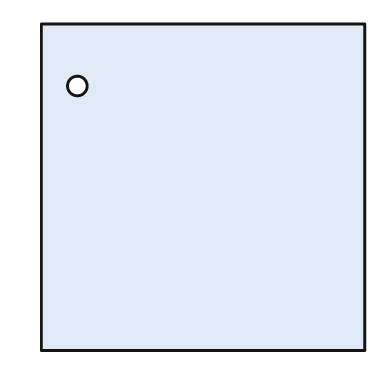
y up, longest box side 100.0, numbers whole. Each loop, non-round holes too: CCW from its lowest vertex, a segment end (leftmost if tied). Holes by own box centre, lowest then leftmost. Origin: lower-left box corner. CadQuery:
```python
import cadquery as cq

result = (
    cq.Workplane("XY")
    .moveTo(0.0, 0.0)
    .lineTo(99.0, 0.0)
    .lineTo(99.0, 100.0)
    .lineTo(0.0, 100.0)
    .close()
    .moveTo(11.0, 81.0)
    .circle(3.0)
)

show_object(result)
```